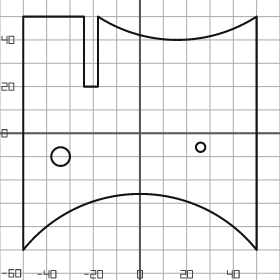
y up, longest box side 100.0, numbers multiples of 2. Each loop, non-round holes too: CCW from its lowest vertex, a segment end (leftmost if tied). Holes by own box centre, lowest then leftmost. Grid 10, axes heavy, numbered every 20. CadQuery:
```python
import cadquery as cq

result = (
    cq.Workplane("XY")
    .moveTo(-50.0, -50.0)
    .threePointArc((0.0, -26.0), (50.0, -50.0))
    .lineTo(50.0, 50.0)
    .threePointArc((16.0, 40.0), (-18.0, 50.0))
    .lineTo(-18.0, 20.0)
    .lineTo(-24.0, 20.0)
    .lineTo(-24.0, 50.0)
    .lineTo(-50.0, 50.0)
    .close()
    .moveTo(-34.0, -10.0)
    .circle(4.0)
    .moveTo(26.0, -6.0)
    .circle(2.0)
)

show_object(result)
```